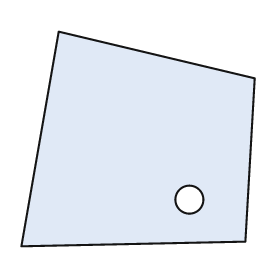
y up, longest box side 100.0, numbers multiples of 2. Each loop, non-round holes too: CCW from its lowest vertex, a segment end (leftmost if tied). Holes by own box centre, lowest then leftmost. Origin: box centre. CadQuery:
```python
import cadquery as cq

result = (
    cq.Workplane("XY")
    .moveTo(-50.0, -46.0)
    .lineTo(46.0, -44.0)
    .lineTo(50.0, 26.0)
    .lineTo(-34.0, 46.0)
    .close()
    .moveTo(22.0, -26.0)
    .circle(6.0)
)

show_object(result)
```